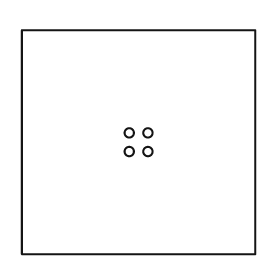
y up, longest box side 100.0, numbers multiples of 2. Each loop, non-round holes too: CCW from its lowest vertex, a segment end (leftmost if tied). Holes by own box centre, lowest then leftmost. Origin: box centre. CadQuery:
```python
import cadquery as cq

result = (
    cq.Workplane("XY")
    .moveTo(-50.0, -48.0)
    .lineTo(50.0, -48.0)
    .lineTo(50.0, 48.0)
    .lineTo(-50.0, 48.0)
    .close()
    .moveTo(-4.0, -4.0)
    .circle(2.0)
    .moveTo(4.0, -4.0)
    .circle(2.0)
    .moveTo(-4.0, 4.0)
    .circle(2.0)
    .moveTo(4.0, 4.0)
    .circle(2.0)
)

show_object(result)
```